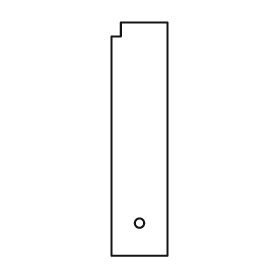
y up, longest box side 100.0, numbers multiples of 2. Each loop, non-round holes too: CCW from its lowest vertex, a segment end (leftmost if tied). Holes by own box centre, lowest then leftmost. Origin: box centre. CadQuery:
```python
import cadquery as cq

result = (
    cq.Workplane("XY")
    .moveTo(-12.0, -50.0)
    .lineTo(12.0, -50.0)
    .lineTo(12.0, 50.0)
    .lineTo(-8.0, 50.0)
    .lineTo(-8.0, 44.0)
    .lineTo(-12.0, 44.0)
    .close()
    .moveTo(0.0, -36.0)
    .circle(2.0)
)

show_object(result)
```